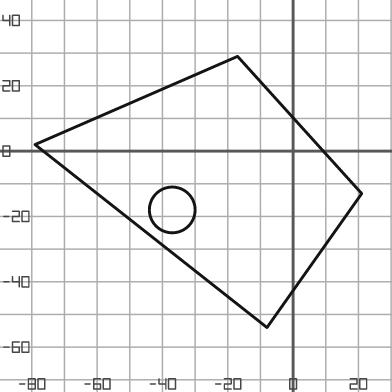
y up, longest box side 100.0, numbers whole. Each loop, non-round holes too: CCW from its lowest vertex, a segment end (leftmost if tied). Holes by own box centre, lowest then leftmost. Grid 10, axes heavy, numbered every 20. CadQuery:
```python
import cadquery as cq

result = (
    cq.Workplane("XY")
    .moveTo(-8.0, -54.0)
    .lineTo(21.0, -13.0)
    .lineTo(-17.0, 29.0)
    .lineTo(-79.0, 2.0)
    .close()
    .moveTo(-37.0, -18.0)
    .circle(7.0)
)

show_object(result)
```